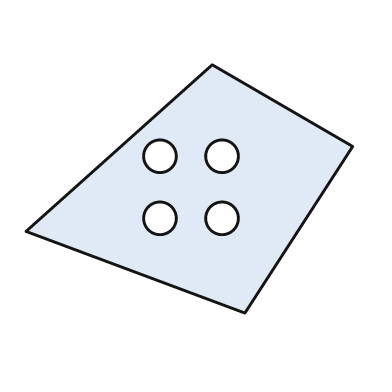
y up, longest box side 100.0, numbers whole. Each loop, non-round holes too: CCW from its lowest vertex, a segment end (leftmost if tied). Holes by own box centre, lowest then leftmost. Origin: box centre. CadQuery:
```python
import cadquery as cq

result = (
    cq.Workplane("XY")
    .moveTo(17.0, -38.0)
    .lineTo(50.0, 13.0)
    .lineTo(7.0, 38.0)
    .lineTo(-50.0, -13.0)
    .close()
    .moveTo(-9.0, -9.0)
    .circle(5.0)
    .moveTo(10.0, -9.0)
    .circle(5.0)
    .moveTo(-9.0, 10.0)
    .circle(5.0)
    .moveTo(10.0, 10.0)
    .circle(5.0)
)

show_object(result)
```